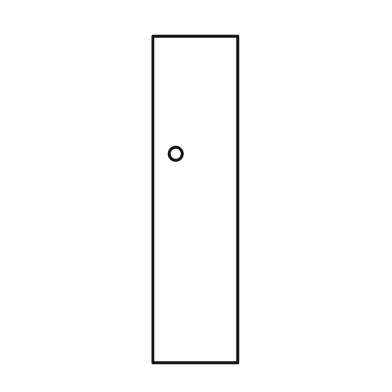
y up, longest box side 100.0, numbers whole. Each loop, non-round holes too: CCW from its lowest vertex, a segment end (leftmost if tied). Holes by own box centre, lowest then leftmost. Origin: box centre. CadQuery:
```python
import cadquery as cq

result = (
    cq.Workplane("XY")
    .moveTo(-13.0, -50.0)
    .lineTo(13.0, -50.0)
    .lineTo(13.0, 50.0)
    .lineTo(-13.0, 50.0)
    .close()
    .moveTo(-6.0, 14.0)
    .circle(2.0)
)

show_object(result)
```